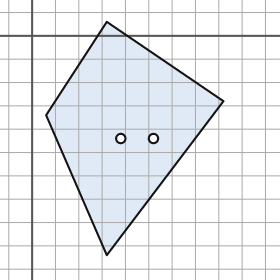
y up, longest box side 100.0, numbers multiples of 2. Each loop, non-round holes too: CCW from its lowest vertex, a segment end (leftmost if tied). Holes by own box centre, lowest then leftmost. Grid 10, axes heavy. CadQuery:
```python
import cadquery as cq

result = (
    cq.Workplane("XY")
    .moveTo(32.0, -94.0)
    .lineTo(82.0, -28.0)
    .lineTo(32.0, 6.0)
    .lineTo(6.0, -34.0)
    .close()
    .moveTo(38.0, -44.0)
    .circle(2.0)
    .moveTo(52.0, -44.0)
    .circle(2.0)
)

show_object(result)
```